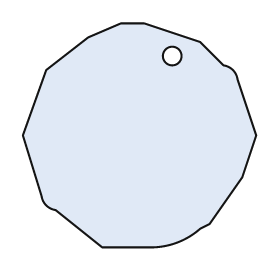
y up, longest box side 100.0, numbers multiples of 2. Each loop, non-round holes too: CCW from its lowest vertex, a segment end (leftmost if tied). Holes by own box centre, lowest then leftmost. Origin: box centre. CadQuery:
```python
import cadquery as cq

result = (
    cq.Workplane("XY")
    .moveTo(-16.0, -48.0)
    .lineTo(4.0, -48.0)
    .threePointArc((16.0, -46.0), (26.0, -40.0))
    .lineTo(30.0, -38.0)
    .lineTo(44.0, -18.0)
    .lineTo(50.0, 0.0)
    .lineTo(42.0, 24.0)
    .threePointArc((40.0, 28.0), (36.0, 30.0))
    .lineTo(26.0, 40.0)
    .lineTo(2.0, 48.0)
    .lineTo(-8.0, 48.0)
    .lineTo(-22.0, 42.0)
    .lineTo(-40.0, 28.0)
    .lineTo(-50.0, 0.0)
    .lineTo(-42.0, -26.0)
    .threePointArc((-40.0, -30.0), (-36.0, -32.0))
    .close()
    .moveTo(14.0, 34.0)
    .circle(4.0)
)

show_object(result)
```